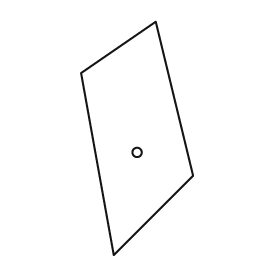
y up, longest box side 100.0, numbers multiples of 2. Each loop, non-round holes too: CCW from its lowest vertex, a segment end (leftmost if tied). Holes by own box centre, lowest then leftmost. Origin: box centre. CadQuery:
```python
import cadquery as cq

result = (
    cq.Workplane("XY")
    .moveTo(-10.0, -50.0)
    .lineTo(24.0, -16.0)
    .lineTo(8.0, 50.0)
    .lineTo(-24.0, 28.0)
    .close()
    .moveTo(0.0, -6.0)
    .circle(2.0)
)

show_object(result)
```